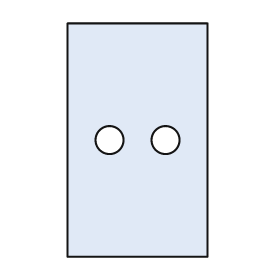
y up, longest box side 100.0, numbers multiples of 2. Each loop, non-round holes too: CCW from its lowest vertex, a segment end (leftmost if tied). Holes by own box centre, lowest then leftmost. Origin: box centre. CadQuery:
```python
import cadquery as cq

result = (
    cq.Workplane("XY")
    .moveTo(-30.0, -50.0)
    .lineTo(30.0, -50.0)
    .lineTo(30.0, 50.0)
    .lineTo(-30.0, 50.0)
    .close()
    .moveTo(-12.0, 0.0)
    .circle(6.0)
    .moveTo(12.0, 0.0)
    .circle(6.0)
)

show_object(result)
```